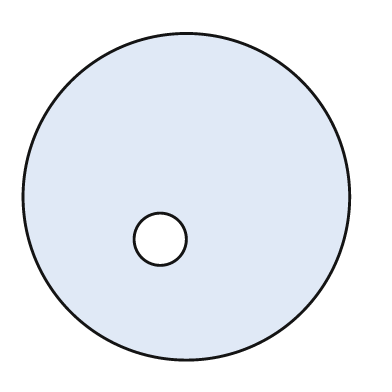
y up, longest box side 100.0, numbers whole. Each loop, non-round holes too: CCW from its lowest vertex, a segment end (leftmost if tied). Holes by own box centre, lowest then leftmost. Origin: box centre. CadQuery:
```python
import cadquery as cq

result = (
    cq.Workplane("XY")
    .moveTo(0.0, 0.0)
    .circle(50.0)
    .moveTo(-8.0, -13.0)
    .circle(8.0)
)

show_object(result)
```